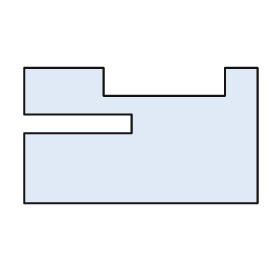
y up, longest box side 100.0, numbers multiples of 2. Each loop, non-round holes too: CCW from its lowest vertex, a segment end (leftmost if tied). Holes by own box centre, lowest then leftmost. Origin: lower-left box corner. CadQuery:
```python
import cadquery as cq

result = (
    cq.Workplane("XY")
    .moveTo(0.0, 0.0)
    .lineTo(100.0, 0.0)
    .lineTo(100.0, 58.0)
    .lineTo(86.0, 58.0)
    .lineTo(86.0, 46.0)
    .lineTo(34.0, 46.0)
    .lineTo(34.0, 58.0)
    .lineTo(0.0, 58.0)
    .lineTo(0.0, 38.0)
    .lineTo(46.0, 38.0)
    .lineTo(46.0, 30.0)
    .lineTo(0.0, 30.0)
    .close()
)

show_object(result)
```